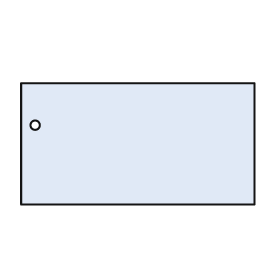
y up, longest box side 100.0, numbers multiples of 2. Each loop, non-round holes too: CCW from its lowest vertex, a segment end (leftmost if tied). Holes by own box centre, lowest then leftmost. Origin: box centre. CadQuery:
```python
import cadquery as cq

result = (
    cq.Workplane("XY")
    .moveTo(-50.0, -26.0)
    .lineTo(50.0, -26.0)
    .lineTo(50.0, 26.0)
    .lineTo(-50.0, 26.0)
    .close()
    .moveTo(-44.0, 8.0)
    .circle(2.0)
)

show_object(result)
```